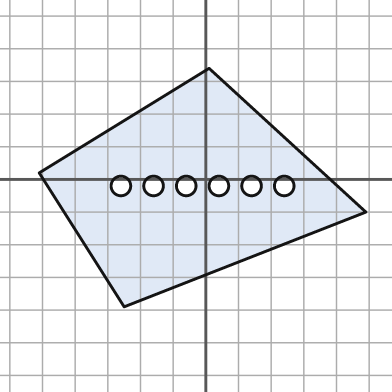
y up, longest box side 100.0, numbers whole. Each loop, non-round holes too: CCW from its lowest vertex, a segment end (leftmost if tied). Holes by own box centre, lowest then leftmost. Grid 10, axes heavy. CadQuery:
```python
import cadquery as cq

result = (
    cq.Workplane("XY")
    .moveTo(-25.0, -39.0)
    .lineTo(49.0, -10.0)
    .lineTo(1.0, 34.0)
    .lineTo(-51.0, 2.0)
    .close()
    .moveTo(-26.0, -2.0)
    .circle(3.0)
    .moveTo(-16.0, -2.0)
    .circle(3.0)
    .moveTo(-6.0, -2.0)
    .circle(3.0)
    .moveTo(4.0, -2.0)
    .circle(3.0)
    .moveTo(14.0, -2.0)
    .circle(3.0)
    .moveTo(24.0, -2.0)
    .circle(3.0)
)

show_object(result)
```